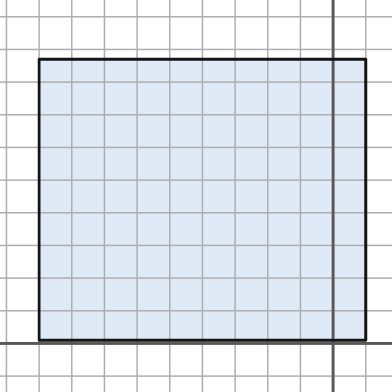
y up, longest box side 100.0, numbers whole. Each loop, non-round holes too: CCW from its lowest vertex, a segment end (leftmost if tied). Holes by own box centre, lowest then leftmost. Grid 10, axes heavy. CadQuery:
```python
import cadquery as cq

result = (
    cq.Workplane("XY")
    .moveTo(-90.0, 1.0)
    .lineTo(10.0, 1.0)
    .lineTo(10.0, 87.0)
    .lineTo(-90.0, 87.0)
    .close()
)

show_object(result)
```